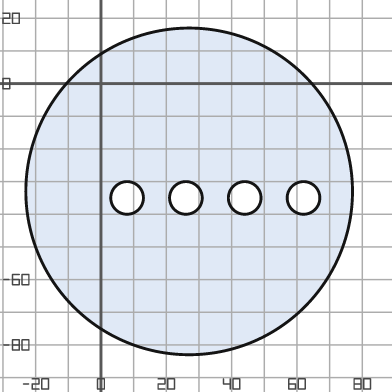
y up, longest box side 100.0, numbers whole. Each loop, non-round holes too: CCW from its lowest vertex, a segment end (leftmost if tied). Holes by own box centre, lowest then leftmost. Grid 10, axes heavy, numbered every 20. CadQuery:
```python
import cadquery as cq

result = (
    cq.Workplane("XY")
    .moveTo(27.0, -33.0)
    .circle(50.0)
    .moveTo(8.0, -35.0)
    .circle(5.0)
    .moveTo(26.0, -35.0)
    .circle(5.0)
    .moveTo(44.0, -35.0)
    .circle(5.0)
    .moveTo(62.0, -35.0)
    .circle(5.0)
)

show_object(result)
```